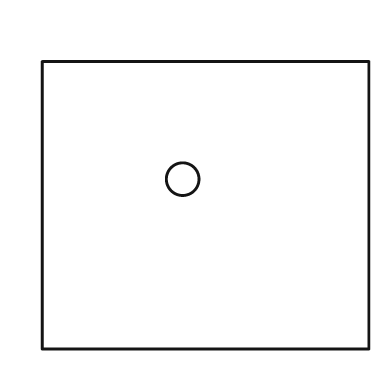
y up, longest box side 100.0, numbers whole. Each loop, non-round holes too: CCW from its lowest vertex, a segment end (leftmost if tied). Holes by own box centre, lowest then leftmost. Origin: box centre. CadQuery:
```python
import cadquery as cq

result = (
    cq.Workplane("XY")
    .moveTo(-50.0, -44.0)
    .lineTo(50.0, -44.0)
    .lineTo(50.0, 44.0)
    .lineTo(-50.0, 44.0)
    .close()
    .moveTo(-7.0, 8.0)
    .circle(5.0)
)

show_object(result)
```